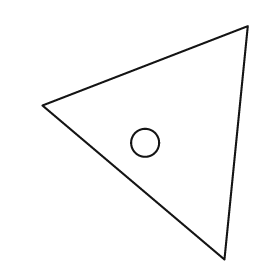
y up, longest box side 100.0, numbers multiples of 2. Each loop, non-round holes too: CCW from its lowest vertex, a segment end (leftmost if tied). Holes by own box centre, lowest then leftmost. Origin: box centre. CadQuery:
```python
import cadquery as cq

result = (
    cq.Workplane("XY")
    .moveTo(34.0, -50.0)
    .lineTo(44.0, 50.0)
    .lineTo(-44.0, 16.0)
    .close()
    .moveTo(0.0, 0.0)
    .circle(6.0)
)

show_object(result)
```